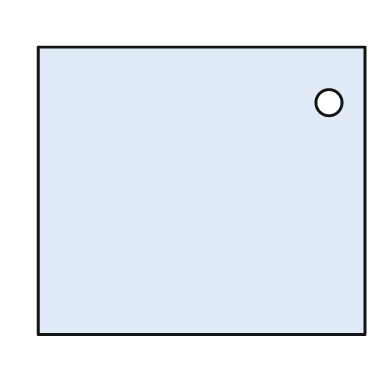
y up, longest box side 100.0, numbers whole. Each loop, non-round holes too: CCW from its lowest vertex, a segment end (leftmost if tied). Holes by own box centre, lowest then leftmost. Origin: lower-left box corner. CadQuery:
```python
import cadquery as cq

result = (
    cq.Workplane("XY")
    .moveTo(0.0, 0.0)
    .lineTo(100.0, 0.0)
    .lineTo(100.0, 88.0)
    .lineTo(0.0, 88.0)
    .close()
    .moveTo(89.0, 71.0)
    .circle(4.0)
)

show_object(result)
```